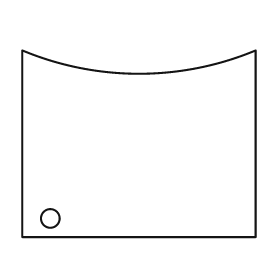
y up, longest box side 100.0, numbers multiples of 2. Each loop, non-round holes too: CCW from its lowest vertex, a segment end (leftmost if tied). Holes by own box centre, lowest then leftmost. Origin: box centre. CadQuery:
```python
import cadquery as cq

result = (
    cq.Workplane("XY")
    .moveTo(-50.0, -40.0)
    .lineTo(50.0, -40.0)
    .lineTo(50.0, 40.0)
    .threePointArc((0.0, 30.0), (-50.0, 40.0))
    .close()
    .moveTo(-38.0, -32.0)
    .circle(4.0)
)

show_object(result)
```